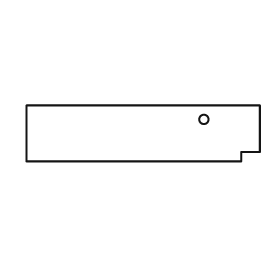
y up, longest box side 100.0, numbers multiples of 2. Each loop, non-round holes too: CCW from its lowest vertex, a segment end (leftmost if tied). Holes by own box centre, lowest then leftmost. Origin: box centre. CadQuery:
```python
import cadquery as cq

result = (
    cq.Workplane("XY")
    .moveTo(-50.0, -12.0)
    .lineTo(42.0, -12.0)
    .lineTo(42.0, -8.0)
    .lineTo(50.0, -8.0)
    .lineTo(50.0, 12.0)
    .lineTo(-50.0, 12.0)
    .close()
    .moveTo(26.0, 6.0)
    .circle(2.0)
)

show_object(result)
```